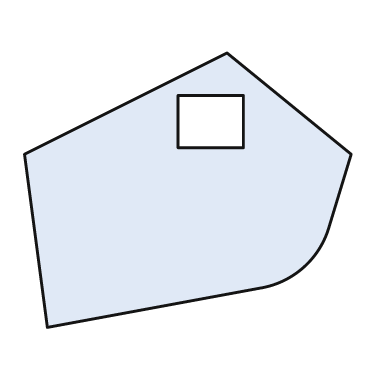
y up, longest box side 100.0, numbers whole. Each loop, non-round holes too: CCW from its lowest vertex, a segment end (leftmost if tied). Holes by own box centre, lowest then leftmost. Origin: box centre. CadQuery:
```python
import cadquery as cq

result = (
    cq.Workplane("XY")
    .moveTo(-43.0, -42.0)
    .lineTo(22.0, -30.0)
    .threePointArc((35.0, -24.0), (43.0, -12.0))
    .lineTo(50.0, 11.0)
    .lineTo(12.0, 42.0)
    .lineTo(-50.0, 11.0)
    .close()
    .moveTo(-3.0, 13.0)
    .lineTo(17.0, 13.0)
    .lineTo(17.0, 29.0)
    .lineTo(-3.0, 29.0)
    .close()
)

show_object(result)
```